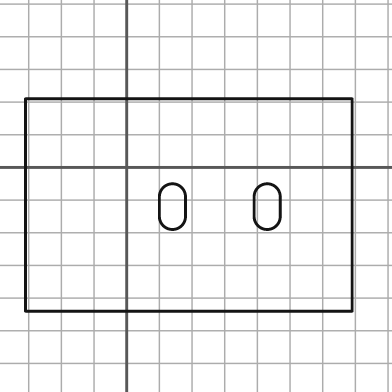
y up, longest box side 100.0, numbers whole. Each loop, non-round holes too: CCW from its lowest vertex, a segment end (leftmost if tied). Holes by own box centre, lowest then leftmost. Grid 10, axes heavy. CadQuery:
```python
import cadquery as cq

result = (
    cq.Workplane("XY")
    .moveTo(-31.0, -44.0)
    .lineTo(69.0, -44.0)
    .lineTo(69.0, 21.0)
    .lineTo(-31.0, 21.0)
    .close()
    .moveTo(10.0, -15.0)
    .threePointArc((14.0, -19.0), (18.0, -15.0))
    .lineTo(18.0, -9.0)
    .threePointArc((14.0, -5.0), (10.0, -9.0))
    .close()
    .moveTo(39.0, -15.0)
    .threePointArc((43.0, -19.0), (47.0, -15.0))
    .lineTo(47.0, -9.0)
    .threePointArc((43.0, -5.0), (39.0, -9.0))
    .close()
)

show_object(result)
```